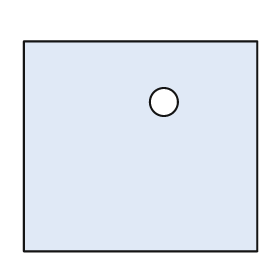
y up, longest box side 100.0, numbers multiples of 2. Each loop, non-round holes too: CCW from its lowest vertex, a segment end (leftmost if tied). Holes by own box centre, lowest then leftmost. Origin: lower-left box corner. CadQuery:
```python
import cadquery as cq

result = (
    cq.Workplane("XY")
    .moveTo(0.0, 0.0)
    .lineTo(100.0, 0.0)
    .lineTo(100.0, 90.0)
    .lineTo(0.0, 90.0)
    .close()
    .moveTo(60.0, 64.0)
    .circle(6.0)
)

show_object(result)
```